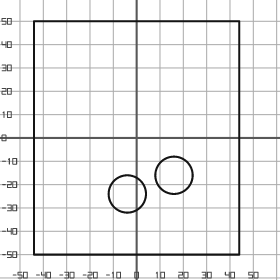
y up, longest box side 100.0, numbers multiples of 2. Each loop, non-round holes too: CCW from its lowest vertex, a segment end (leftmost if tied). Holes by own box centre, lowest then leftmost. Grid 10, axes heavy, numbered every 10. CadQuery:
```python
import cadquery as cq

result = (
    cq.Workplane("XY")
    .moveTo(-44.0, -50.0)
    .lineTo(44.0, -50.0)
    .lineTo(44.0, 50.0)
    .lineTo(-44.0, 50.0)
    .close()
    .moveTo(-4.0, -24.0)
    .circle(8.0)
    .moveTo(16.0, -16.0)
    .circle(8.0)
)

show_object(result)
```